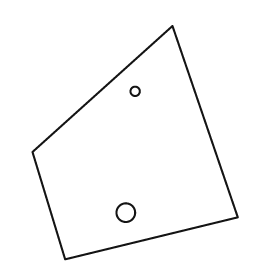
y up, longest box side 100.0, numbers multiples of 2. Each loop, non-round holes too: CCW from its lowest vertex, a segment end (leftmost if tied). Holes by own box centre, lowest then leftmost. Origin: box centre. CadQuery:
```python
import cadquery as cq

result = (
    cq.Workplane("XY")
    .moveTo(-30.0, -50.0)
    .lineTo(44.0, -32.0)
    .lineTo(16.0, 50.0)
    .lineTo(-44.0, -4.0)
    .close()
    .moveTo(-4.0, -30.0)
    .circle(4.0)
    .moveTo(0.0, 22.0)
    .circle(2.0)
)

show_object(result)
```